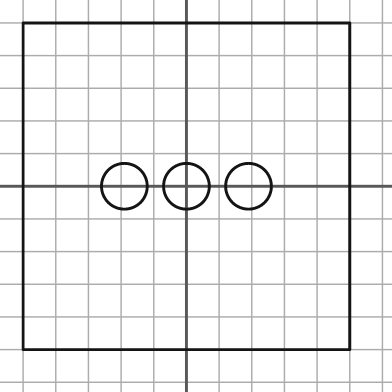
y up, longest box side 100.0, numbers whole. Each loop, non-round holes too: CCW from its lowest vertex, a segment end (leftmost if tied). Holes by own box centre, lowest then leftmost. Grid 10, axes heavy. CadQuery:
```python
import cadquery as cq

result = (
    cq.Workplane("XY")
    .moveTo(-50.0, -50.0)
    .lineTo(50.0, -50.0)
    .lineTo(50.0, 50.0)
    .lineTo(-50.0, 50.0)
    .close()
    .moveTo(-19.0, 0.0)
    .circle(7.0)
    .moveTo(0.0, 0.0)
    .circle(7.0)
    .moveTo(19.0, 0.0)
    .circle(7.0)
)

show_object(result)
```